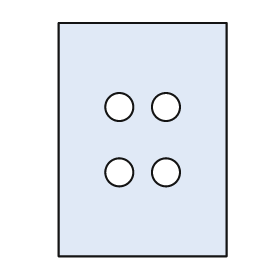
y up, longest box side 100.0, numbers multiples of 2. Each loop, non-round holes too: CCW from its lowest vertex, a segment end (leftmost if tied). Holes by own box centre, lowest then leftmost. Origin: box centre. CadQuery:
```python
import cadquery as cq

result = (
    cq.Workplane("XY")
    .moveTo(-36.0, -50.0)
    .lineTo(36.0, -50.0)
    .lineTo(36.0, 50.0)
    .lineTo(-36.0, 50.0)
    .close()
    .moveTo(-10.0, -14.0)
    .circle(6.0)
    .moveTo(10.0, -14.0)
    .circle(6.0)
    .moveTo(-10.0, 14.0)
    .circle(6.0)
    .moveTo(10.0, 14.0)
    .circle(6.0)
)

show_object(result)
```